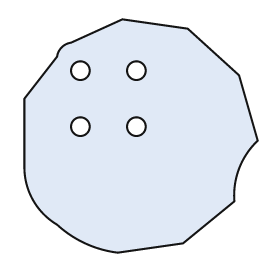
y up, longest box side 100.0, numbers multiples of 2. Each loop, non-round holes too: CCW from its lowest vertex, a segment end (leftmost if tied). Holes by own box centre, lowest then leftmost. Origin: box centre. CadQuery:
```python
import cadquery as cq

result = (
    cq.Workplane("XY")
    .moveTo(-10.0, -50.0)
    .lineTo(18.0, -46.0)
    .lineTo(40.0, -28.0)
    .threePointArc((42.0, -14.0), (50.0, -2.0))
    .lineTo(42.0, 26.0)
    .lineTo(20.0, 46.0)
    .lineTo(-8.0, 50.0)
    .lineTo(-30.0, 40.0)
    .threePointArc((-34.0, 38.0), (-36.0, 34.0))
    .lineTo(-50.0, 16.0)
    .lineTo(-50.0, -14.0)
    .threePointArc((-46.0, -28.0), (-36.0, -38.0))
    .threePointArc((-24.0, -46.0), (-10.0, -50.0))
    .close()
    .moveTo(-26.0, 4.0)
    .circle(4.0)
    .moveTo(-2.0, 4.0)
    .circle(4.0)
    .moveTo(-26.0, 28.0)
    .circle(4.0)
    .moveTo(-2.0, 28.0)
    .circle(4.0)
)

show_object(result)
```